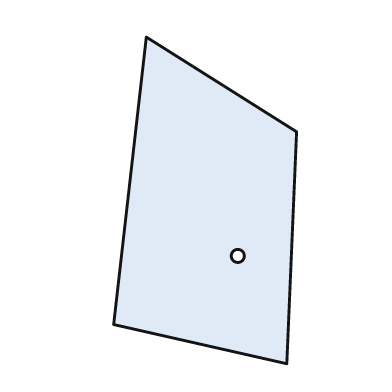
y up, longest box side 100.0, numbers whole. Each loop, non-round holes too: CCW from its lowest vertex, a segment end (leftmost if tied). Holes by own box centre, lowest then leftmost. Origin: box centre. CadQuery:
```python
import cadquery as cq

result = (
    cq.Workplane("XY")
    .moveTo(25.0, -50.0)
    .lineTo(28.0, 21.0)
    .lineTo(-18.0, 50.0)
    .lineTo(-28.0, -38.0)
    .close()
    .moveTo(10.0, -17.0)
    .circle(2.0)
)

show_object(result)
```